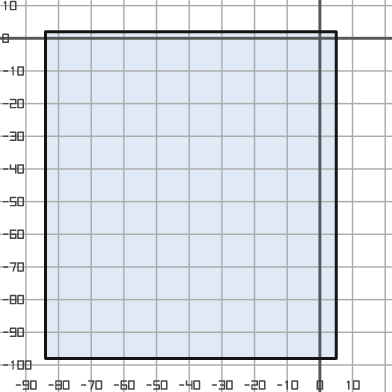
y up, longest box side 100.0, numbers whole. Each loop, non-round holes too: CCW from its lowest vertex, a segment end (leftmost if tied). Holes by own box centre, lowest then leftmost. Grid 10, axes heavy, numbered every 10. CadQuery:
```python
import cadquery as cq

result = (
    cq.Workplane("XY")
    .moveTo(-84.0, -98.0)
    .lineTo(5.0, -98.0)
    .lineTo(5.0, 2.0)
    .lineTo(-84.0, 2.0)
    .close()
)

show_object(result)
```